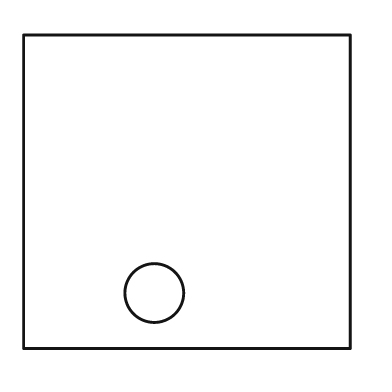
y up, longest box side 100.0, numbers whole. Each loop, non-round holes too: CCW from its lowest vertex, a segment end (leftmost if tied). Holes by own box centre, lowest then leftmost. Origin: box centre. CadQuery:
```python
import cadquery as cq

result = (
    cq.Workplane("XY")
    .moveTo(-50.0, -48.0)
    .lineTo(50.0, -48.0)
    .lineTo(50.0, 48.0)
    .lineTo(-50.0, 48.0)
    .close()
    .moveTo(-10.0, -31.0)
    .circle(9.0)
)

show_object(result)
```